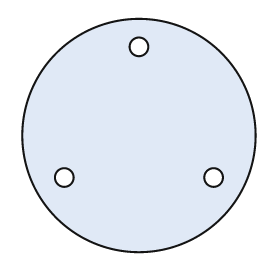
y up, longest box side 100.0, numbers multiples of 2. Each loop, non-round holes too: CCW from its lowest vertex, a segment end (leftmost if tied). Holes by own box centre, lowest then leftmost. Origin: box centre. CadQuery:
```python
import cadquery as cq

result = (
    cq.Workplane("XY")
    .moveTo(0.0, 0.0)
    .circle(50.0)
    .moveTo(-32.0, -18.0)
    .circle(4.0)
    .moveTo(32.0, -18.0)
    .circle(4.0)
    .moveTo(0.0, 38.0)
    .circle(4.0)
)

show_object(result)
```